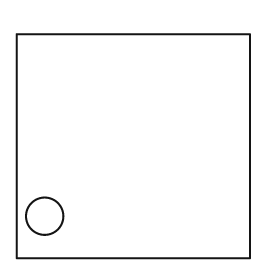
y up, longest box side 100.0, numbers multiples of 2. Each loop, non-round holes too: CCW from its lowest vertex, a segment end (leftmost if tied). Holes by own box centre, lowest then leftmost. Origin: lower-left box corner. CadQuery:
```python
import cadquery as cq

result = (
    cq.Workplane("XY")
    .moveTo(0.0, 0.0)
    .lineTo(100.0, 0.0)
    .lineTo(100.0, 96.0)
    .lineTo(0.0, 96.0)
    .close()
    .moveTo(12.0, 18.0)
    .circle(8.0)
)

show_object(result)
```